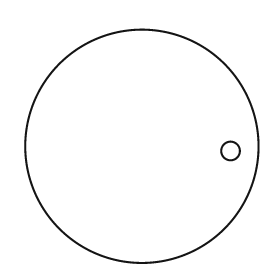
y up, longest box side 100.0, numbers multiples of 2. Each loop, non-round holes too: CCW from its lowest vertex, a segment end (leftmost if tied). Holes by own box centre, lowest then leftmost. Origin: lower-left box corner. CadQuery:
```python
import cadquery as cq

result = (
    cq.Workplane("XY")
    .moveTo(50.0, 50.0)
    .circle(50.0)
    .moveTo(88.0, 48.0)
    .circle(4.0)
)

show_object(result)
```